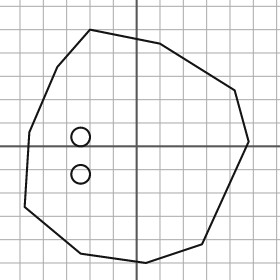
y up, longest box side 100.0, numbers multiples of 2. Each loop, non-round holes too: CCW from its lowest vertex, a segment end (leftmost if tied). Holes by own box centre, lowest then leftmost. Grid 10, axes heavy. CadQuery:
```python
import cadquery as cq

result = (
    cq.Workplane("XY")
    .moveTo(4.0, -50.0)
    .lineTo(28.0, -42.0)
    .lineTo(48.0, 2.0)
    .lineTo(42.0, 24.0)
    .lineTo(10.0, 44.0)
    .lineTo(-20.0, 50.0)
    .lineTo(-34.0, 34.0)
    .lineTo(-46.0, 6.0)
    .lineTo(-48.0, -26.0)
    .lineTo(-24.0, -46.0)
    .close()
    .moveTo(-24.0, -12.0)
    .circle(4.0)
    .moveTo(-24.0, 4.0)
    .circle(4.0)
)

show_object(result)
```